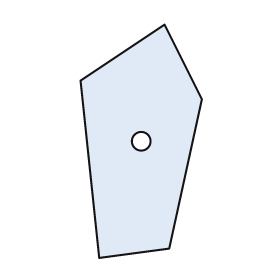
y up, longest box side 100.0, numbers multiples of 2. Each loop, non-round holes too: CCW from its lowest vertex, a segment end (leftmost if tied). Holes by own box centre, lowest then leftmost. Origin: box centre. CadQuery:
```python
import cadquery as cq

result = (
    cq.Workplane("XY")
    .moveTo(-18.0, -50.0)
    .lineTo(12.0, -46.0)
    .lineTo(26.0, 18.0)
    .lineTo(10.0, 50.0)
    .lineTo(-26.0, 26.0)
    .close()
    .moveTo(0.0, 0.0)
    .circle(4.0)
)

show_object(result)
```